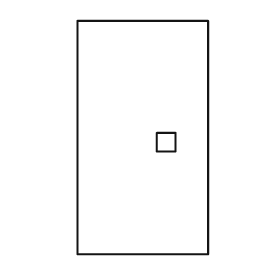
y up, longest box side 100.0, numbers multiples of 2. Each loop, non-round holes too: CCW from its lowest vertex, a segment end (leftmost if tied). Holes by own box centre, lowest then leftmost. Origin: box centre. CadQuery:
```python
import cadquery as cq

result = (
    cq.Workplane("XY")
    .moveTo(-28.0, -50.0)
    .lineTo(28.0, -50.0)
    .lineTo(28.0, 50.0)
    .lineTo(-28.0, 50.0)
    .close()
    .moveTo(6.0, -6.0)
    .lineTo(14.0, -6.0)
    .lineTo(14.0, 2.0)
    .lineTo(6.0, 2.0)
    .close()
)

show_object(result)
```